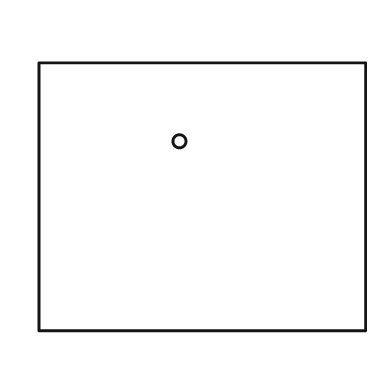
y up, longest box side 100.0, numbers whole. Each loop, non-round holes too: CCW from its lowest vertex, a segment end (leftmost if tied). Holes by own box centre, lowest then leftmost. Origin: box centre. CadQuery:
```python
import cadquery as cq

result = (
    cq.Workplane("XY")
    .moveTo(-50.0, -41.0)
    .lineTo(50.0, -41.0)
    .lineTo(50.0, 41.0)
    .lineTo(-50.0, 41.0)
    .close()
    .moveTo(-7.0, 17.0)
    .circle(2.0)
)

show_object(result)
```